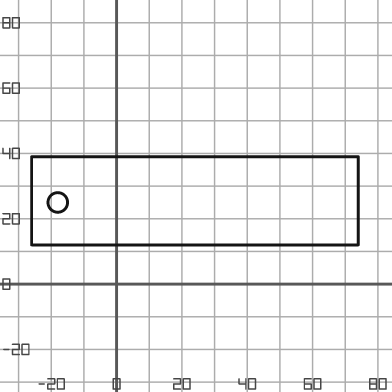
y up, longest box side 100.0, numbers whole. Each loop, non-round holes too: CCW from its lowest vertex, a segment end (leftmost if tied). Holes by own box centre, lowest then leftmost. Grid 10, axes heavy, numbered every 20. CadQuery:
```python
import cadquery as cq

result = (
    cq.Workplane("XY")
    .moveTo(-26.0, 12.0)
    .lineTo(74.0, 12.0)
    .lineTo(74.0, 39.0)
    .lineTo(-26.0, 39.0)
    .close()
    .moveTo(-18.0, 25.0)
    .circle(3.0)
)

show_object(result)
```